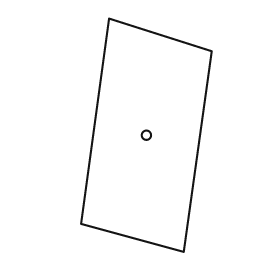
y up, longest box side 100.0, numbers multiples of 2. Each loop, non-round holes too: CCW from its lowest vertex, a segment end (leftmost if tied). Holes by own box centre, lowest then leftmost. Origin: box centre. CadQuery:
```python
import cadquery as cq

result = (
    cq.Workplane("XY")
    .moveTo(16.0, -50.0)
    .lineTo(28.0, 36.0)
    .lineTo(-16.0, 50.0)
    .lineTo(-28.0, -38.0)
    .close()
    .moveTo(0.0, 0.0)
    .circle(2.0)
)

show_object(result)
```